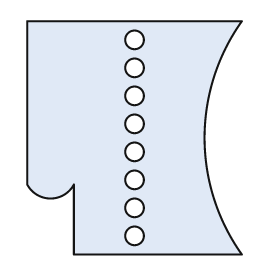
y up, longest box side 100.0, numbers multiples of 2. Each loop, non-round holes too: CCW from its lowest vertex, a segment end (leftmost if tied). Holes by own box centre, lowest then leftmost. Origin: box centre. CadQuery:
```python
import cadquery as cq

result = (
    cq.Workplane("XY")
    .moveTo(-26.0, -50.0)
    .lineTo(46.0, -50.0)
    .threePointArc((30.0, 0.0), (46.0, 50.0))
    .lineTo(-46.0, 50.0)
    .lineTo(-46.0, -20.0)
    .threePointArc((-36.0, -26.0), (-26.0, -20.0))
    .close()
    .moveTo(0.0, -42.0)
    .circle(4.0)
    .moveTo(0.0, -30.0)
    .circle(4.0)
    .moveTo(0.0, -18.0)
    .circle(4.0)
    .moveTo(0.0, -6.0)
    .circle(4.0)
    .moveTo(0.0, 6.0)
    .circle(4.0)
    .moveTo(0.0, 18.0)
    .circle(4.0)
    .moveTo(0.0, 30.0)
    .circle(4.0)
    .moveTo(0.0, 42.0)
    .circle(4.0)
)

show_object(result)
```